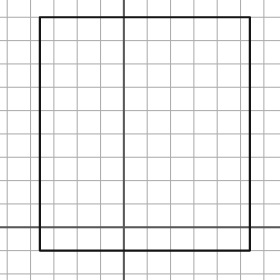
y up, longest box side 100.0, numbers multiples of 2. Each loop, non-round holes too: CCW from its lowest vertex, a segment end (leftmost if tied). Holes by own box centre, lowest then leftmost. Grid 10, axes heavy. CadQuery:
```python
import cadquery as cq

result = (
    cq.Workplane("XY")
    .moveTo(-36.0, -10.0)
    .lineTo(54.0, -10.0)
    .lineTo(54.0, 90.0)
    .lineTo(-36.0, 90.0)
    .close()
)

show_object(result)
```